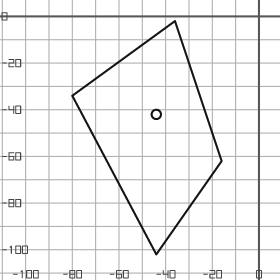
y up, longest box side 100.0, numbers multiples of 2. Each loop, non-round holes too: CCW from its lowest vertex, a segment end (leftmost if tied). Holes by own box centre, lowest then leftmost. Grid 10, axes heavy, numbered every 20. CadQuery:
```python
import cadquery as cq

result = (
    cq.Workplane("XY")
    .moveTo(-44.0, -102.0)
    .lineTo(-16.0, -62.0)
    .lineTo(-36.0, -2.0)
    .lineTo(-80.0, -34.0)
    .close()
    .moveTo(-44.0, -42.0)
    .circle(2.0)
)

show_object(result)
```